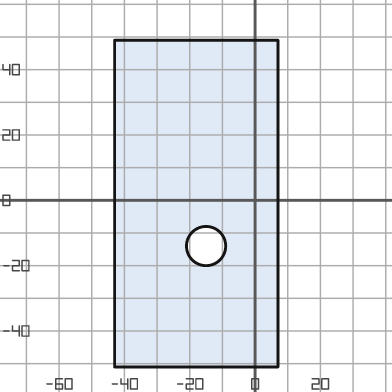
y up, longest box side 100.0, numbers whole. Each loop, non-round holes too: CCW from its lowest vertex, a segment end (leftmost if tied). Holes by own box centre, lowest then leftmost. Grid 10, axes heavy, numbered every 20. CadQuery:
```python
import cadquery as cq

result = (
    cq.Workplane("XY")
    .moveTo(-43.0, -51.0)
    .lineTo(7.0, -51.0)
    .lineTo(7.0, 49.0)
    .lineTo(-43.0, 49.0)
    .close()
    .moveTo(-15.0, -14.0)
    .circle(6.0)
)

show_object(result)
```